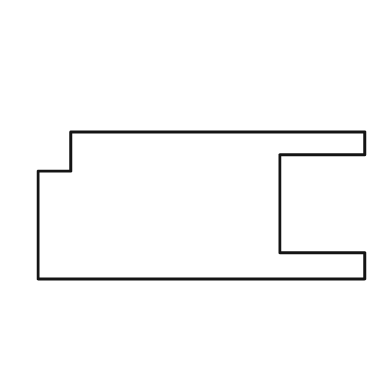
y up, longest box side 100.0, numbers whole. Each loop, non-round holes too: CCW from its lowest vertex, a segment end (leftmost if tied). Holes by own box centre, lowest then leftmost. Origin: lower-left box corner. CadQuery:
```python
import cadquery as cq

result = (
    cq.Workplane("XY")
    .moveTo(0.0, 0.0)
    .lineTo(100.0, 0.0)
    .lineTo(100.0, 8.0)
    .lineTo(74.0, 8.0)
    .lineTo(74.0, 38.0)
    .lineTo(100.0, 38.0)
    .lineTo(100.0, 45.0)
    .lineTo(10.0, 45.0)
    .lineTo(10.0, 33.0)
    .lineTo(0.0, 33.0)
    .close()
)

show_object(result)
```